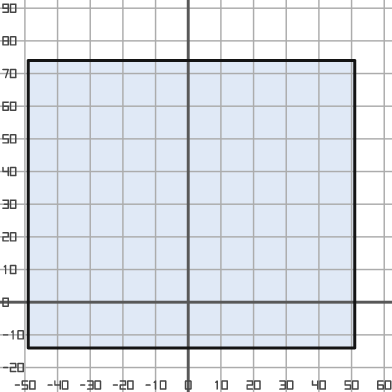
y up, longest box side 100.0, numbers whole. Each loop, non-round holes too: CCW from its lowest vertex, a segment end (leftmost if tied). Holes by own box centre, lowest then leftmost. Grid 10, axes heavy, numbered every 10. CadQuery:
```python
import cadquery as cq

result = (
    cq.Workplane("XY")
    .moveTo(-49.0, -14.0)
    .lineTo(51.0, -14.0)
    .lineTo(51.0, 74.0)
    .lineTo(-49.0, 74.0)
    .close()
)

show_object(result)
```